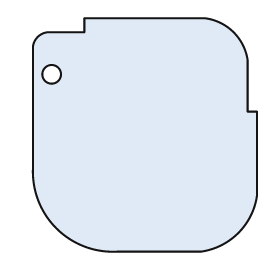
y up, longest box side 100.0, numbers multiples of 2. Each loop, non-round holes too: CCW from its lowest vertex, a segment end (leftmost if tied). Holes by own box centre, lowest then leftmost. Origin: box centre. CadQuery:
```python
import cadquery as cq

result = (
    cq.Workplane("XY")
    .moveTo(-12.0, -50.0)
    .lineTo(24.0, -50.0)
    .threePointArc((40.0, -42.0), (48.0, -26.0))
    .lineTo(48.0, 10.0)
    .lineTo(44.0, 10.0)
    .lineTo(44.0, 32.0)
    .threePointArc((38.0, 44.0), (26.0, 50.0))
    .lineTo(-26.0, 50.0)
    .lineTo(-26.0, 44.0)
    .lineTo(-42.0, 44.0)
    .threePointArc((-46.0, 42.0), (-48.0, 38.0))
    .lineTo(-48.0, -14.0)
    .threePointArc((-38.0, -40.0), (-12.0, -50.0))
    .close()
    .moveTo(-40.0, 26.0)
    .circle(4.0)
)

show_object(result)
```